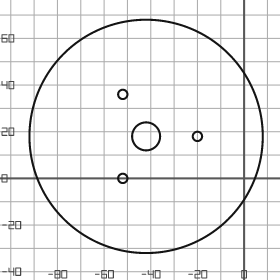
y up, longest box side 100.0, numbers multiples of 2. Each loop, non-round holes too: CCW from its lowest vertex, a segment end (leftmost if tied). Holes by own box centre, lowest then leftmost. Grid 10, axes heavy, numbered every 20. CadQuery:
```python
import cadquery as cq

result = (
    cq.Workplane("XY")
    .moveTo(-42.0, 18.0)
    .circle(50.0)
    .moveTo(-52.0, 0.0)
    .circle(2.0)
    .moveTo(-42.0, 18.0)
    .circle(6.0)
    .moveTo(-20.0, 18.0)
    .circle(2.0)
    .moveTo(-52.0, 36.0)
    .circle(2.0)
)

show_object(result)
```